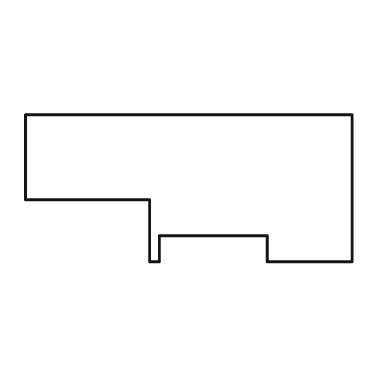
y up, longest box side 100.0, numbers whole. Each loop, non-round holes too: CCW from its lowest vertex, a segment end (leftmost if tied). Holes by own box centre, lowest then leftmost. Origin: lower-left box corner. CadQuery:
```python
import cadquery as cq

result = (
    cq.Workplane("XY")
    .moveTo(38.0, 0.0)
    .lineTo(41.0, 0.0)
    .lineTo(41.0, 8.0)
    .lineTo(74.0, 8.0)
    .lineTo(74.0, 0.0)
    .lineTo(100.0, 0.0)
    .lineTo(100.0, 45.0)
    .lineTo(0.0, 45.0)
    .lineTo(0.0, 19.0)
    .lineTo(38.0, 19.0)
    .close()
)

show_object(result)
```